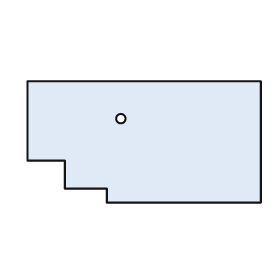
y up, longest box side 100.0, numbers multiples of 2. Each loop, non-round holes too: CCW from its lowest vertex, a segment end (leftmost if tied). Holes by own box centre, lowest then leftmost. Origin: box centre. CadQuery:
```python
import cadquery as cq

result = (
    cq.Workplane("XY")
    .moveTo(-16.0, -26.0)
    .lineTo(50.0, -26.0)
    .lineTo(50.0, 26.0)
    .lineTo(-50.0, 26.0)
    .lineTo(-50.0, -8.0)
    .lineTo(-34.0, -8.0)
    .lineTo(-34.0, -20.0)
    .lineTo(-16.0, -20.0)
    .close()
    .moveTo(-10.0, 10.0)
    .circle(2.0)
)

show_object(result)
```